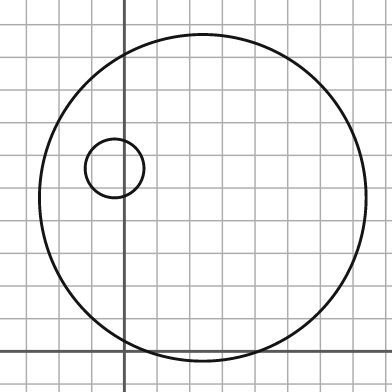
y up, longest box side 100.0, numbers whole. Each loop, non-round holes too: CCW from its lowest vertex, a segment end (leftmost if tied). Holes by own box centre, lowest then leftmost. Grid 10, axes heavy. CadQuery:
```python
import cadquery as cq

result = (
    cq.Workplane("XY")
    .moveTo(24.0, 47.0)
    .circle(50.0)
    .moveTo(-3.0, 56.0)
    .circle(9.0)
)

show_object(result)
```